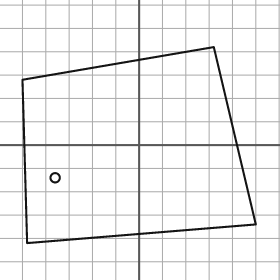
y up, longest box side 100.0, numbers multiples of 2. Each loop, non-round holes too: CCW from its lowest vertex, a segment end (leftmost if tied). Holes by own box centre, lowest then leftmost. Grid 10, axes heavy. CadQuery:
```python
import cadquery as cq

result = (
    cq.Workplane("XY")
    .moveTo(-48.0, -42.0)
    .lineTo(50.0, -34.0)
    .lineTo(32.0, 42.0)
    .lineTo(-50.0, 28.0)
    .close()
    .moveTo(-36.0, -14.0)
    .circle(2.0)
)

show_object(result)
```